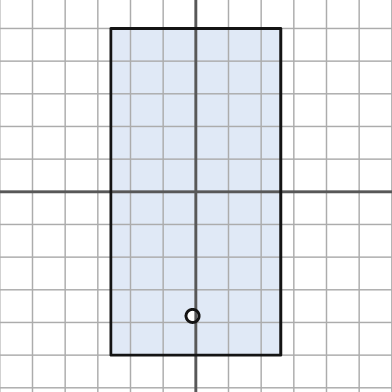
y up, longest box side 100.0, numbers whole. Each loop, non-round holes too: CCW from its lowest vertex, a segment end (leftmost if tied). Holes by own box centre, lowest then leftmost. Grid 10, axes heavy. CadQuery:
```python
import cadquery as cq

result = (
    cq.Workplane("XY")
    .moveTo(-26.0, -50.0)
    .lineTo(26.0, -50.0)
    .lineTo(26.0, 50.0)
    .lineTo(-26.0, 50.0)
    .close()
    .moveTo(-1.0, -38.0)
    .circle(2.0)
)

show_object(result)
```